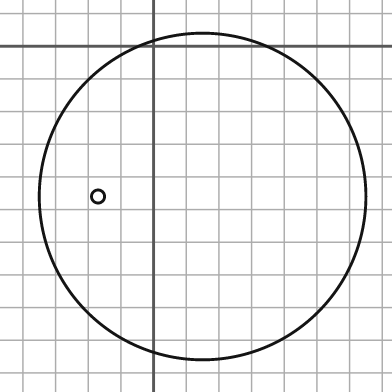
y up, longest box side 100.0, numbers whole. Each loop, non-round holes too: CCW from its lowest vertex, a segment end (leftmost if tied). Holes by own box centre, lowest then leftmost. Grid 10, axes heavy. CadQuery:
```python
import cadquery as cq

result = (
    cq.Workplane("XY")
    .moveTo(15.0, -46.0)
    .circle(50.0)
    .moveTo(-17.0, -46.0)
    .circle(2.0)
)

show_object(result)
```